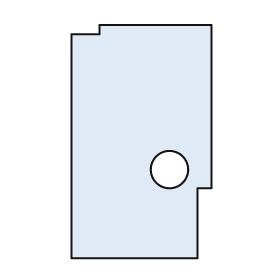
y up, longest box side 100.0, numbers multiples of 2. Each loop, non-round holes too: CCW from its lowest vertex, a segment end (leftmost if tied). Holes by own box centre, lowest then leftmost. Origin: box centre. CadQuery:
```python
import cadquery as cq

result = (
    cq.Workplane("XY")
    .moveTo(-30.0, -50.0)
    .lineTo(24.0, -50.0)
    .lineTo(24.0, -20.0)
    .lineTo(30.0, -20.0)
    .lineTo(30.0, 50.0)
    .lineTo(-18.0, 50.0)
    .lineTo(-18.0, 46.0)
    .lineTo(-30.0, 46.0)
    .close()
    .moveTo(12.0, -12.0)
    .circle(8.0)
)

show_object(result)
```